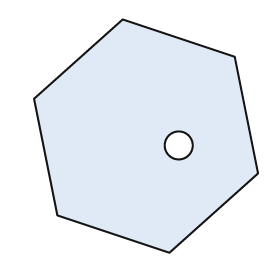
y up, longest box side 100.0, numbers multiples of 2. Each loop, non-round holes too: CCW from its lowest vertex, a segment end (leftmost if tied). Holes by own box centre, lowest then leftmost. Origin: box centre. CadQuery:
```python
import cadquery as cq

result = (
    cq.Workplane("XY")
    .moveTo(10.0, -50.0)
    .lineTo(48.0, -16.0)
    .lineTo(38.0, 34.0)
    .lineTo(-10.0, 50.0)
    .lineTo(-48.0, 16.0)
    .lineTo(-38.0, -34.0)
    .close()
    .moveTo(14.0, -4.0)
    .circle(6.0)
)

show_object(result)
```